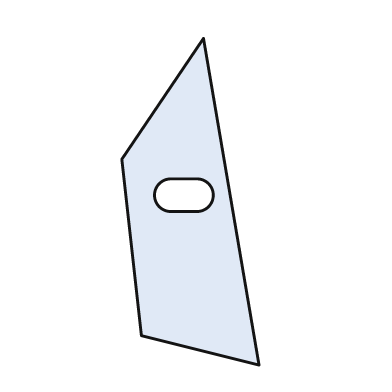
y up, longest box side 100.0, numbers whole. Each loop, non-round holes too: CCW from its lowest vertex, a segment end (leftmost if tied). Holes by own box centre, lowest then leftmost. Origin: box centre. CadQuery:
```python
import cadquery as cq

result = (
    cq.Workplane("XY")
    .moveTo(21.0, -50.0)
    .lineTo(4.0, 50.0)
    .lineTo(-21.0, 13.0)
    .lineTo(-15.0, -41.0)
    .close()
    .moveTo(-6.0, -3.0)
    .lineTo(2.0, -3.0)
    .threePointArc((7.0, 2.0), (2.0, 7.0))
    .lineTo(-6.0, 7.0)
    .threePointArc((-11.0, 2.0), (-6.0, -3.0))
    .close()
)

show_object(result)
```